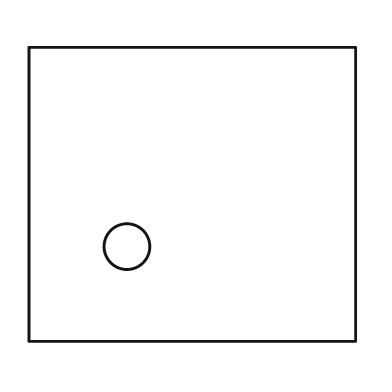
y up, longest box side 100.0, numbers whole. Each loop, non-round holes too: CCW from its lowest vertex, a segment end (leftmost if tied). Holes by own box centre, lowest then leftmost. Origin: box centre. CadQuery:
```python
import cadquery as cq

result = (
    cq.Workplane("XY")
    .moveTo(-50.0, -45.0)
    .lineTo(50.0, -45.0)
    .lineTo(50.0, 45.0)
    .lineTo(-50.0, 45.0)
    .close()
    .moveTo(-20.0, -16.0)
    .circle(7.0)
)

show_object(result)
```